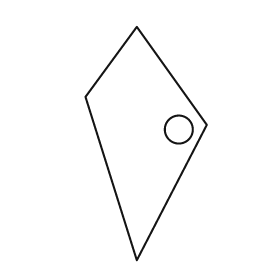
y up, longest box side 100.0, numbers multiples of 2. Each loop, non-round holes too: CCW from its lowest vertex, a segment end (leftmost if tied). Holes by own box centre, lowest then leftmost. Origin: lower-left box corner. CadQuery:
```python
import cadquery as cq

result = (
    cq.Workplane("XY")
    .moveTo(22.0, 0.0)
    .lineTo(52.0, 58.0)
    .lineTo(22.0, 100.0)
    .lineTo(0.0, 70.0)
    .close()
    .moveTo(40.0, 56.0)
    .circle(6.0)
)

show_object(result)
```